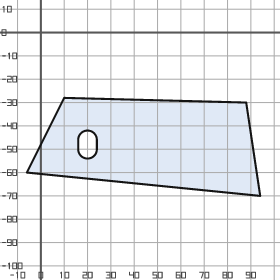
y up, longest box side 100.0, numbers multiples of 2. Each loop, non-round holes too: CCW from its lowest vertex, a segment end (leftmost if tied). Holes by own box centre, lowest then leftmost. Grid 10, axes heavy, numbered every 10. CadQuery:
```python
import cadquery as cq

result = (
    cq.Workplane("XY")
    .moveTo(94.0, -70.0)
    .lineTo(88.0, -30.0)
    .lineTo(10.0, -28.0)
    .lineTo(-6.0, -60.0)
    .close()
    .moveTo(16.0, -50.0)
    .threePointArc((20.0, -54.0), (24.0, -50.0))
    .lineTo(24.0, -46.0)
    .threePointArc((20.0, -42.0), (16.0, -46.0))
    .close()
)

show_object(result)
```